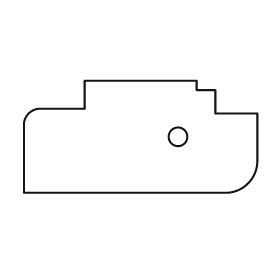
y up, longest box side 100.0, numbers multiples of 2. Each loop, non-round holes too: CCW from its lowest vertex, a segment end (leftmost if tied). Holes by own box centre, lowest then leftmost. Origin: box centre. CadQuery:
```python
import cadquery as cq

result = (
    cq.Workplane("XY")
    .moveTo(-50.0, -24.0)
    .lineTo(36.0, -24.0)
    .threePointArc((46.0, -20.0), (50.0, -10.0))
    .lineTo(50.0, 10.0)
    .lineTo(32.0, 10.0)
    .lineTo(32.0, 20.0)
    .lineTo(24.0, 20.0)
    .lineTo(24.0, 24.0)
    .lineTo(-24.0, 24.0)
    .lineTo(-24.0, 12.0)
    .lineTo(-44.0, 12.0)
    .threePointArc((-48.0, 10.0), (-50.0, 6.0))
    .close()
    .moveTo(16.0, 0.0)
    .circle(4.0)
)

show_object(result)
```